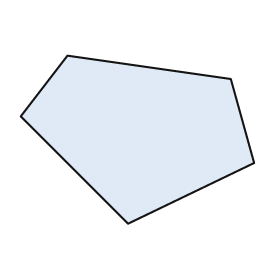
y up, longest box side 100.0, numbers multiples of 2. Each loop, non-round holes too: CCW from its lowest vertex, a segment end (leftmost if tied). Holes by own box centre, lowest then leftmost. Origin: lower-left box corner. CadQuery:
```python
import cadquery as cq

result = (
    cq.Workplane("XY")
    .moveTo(46.0, 0.0)
    .lineTo(100.0, 26.0)
    .lineTo(90.0, 62.0)
    .lineTo(20.0, 72.0)
    .lineTo(0.0, 46.0)
    .close()
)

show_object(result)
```